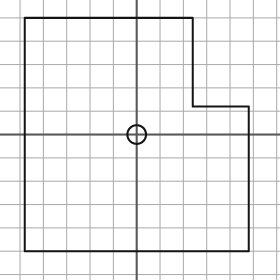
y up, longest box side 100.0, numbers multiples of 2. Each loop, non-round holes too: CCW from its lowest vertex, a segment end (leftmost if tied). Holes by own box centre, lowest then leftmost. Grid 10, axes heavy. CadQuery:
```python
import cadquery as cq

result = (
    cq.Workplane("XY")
    .moveTo(-48.0, -50.0)
    .lineTo(48.0, -50.0)
    .lineTo(48.0, 12.0)
    .lineTo(24.0, 12.0)
    .lineTo(24.0, 50.0)
    .lineTo(-48.0, 50.0)
    .close()
    .moveTo(0.0, 0.0)
    .circle(4.0)
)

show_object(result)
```